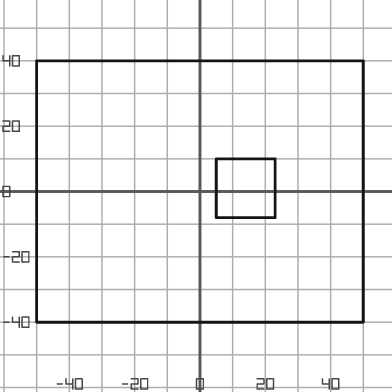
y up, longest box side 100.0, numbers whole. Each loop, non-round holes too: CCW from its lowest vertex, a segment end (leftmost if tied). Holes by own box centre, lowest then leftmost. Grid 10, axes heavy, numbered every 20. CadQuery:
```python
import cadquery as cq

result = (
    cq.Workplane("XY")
    .moveTo(-50.0, -40.0)
    .lineTo(50.0, -40.0)
    .lineTo(50.0, 40.0)
    .lineTo(-50.0, 40.0)
    .close()
    .moveTo(5.0, -8.0)
    .lineTo(23.0, -8.0)
    .lineTo(23.0, 10.0)
    .lineTo(5.0, 10.0)
    .close()
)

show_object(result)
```